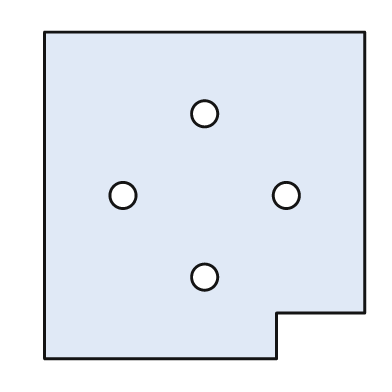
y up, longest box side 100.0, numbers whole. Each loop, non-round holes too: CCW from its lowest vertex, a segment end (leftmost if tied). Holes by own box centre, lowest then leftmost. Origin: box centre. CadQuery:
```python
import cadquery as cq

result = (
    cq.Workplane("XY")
    .moveTo(-49.0, -50.0)
    .lineTo(22.0, -50.0)
    .lineTo(22.0, -36.0)
    .lineTo(49.0, -36.0)
    .lineTo(49.0, 50.0)
    .lineTo(-49.0, 50.0)
    .close()
    .moveTo(0.0, -25.0)
    .circle(4.0)
    .moveTo(-25.0, 0.0)
    .circle(4.0)
    .moveTo(25.0, 0.0)
    .circle(4.0)
    .moveTo(0.0, 25.0)
    .circle(4.0)
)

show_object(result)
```